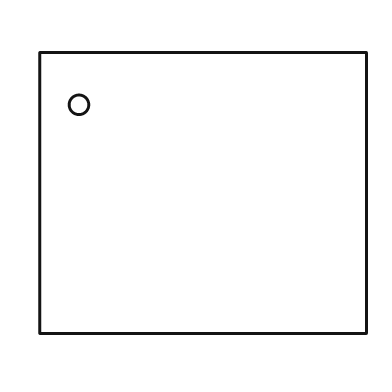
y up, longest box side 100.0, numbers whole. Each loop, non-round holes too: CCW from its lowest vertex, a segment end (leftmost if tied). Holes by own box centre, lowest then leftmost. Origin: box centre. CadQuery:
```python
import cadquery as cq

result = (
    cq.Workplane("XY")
    .moveTo(-50.0, -43.0)
    .lineTo(50.0, -43.0)
    .lineTo(50.0, 43.0)
    .lineTo(-50.0, 43.0)
    .close()
    .moveTo(-38.0, 27.0)
    .circle(3.0)
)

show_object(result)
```